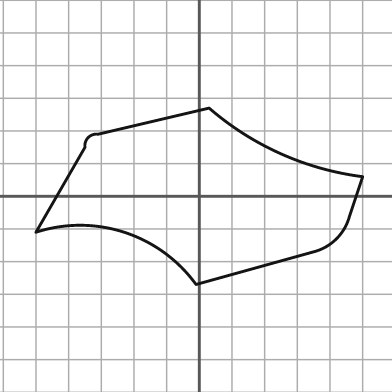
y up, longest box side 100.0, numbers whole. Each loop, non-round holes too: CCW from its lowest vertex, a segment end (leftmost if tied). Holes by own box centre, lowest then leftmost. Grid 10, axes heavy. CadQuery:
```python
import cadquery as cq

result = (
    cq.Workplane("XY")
    .moveTo(-1.0, -27.0)
    .lineTo(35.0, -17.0)
    .threePointArc((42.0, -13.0), (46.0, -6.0))
    .lineTo(50.0, 6.0)
    .threePointArc((25.0, 13.0), (3.0, 27.0))
    .lineTo(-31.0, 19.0)
    .threePointArc((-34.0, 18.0), (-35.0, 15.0))
    .lineTo(-50.0, -11.0)
    .threePointArc((-23.0, -11.0), (-1.0, -27.0))
    .close()
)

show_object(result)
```